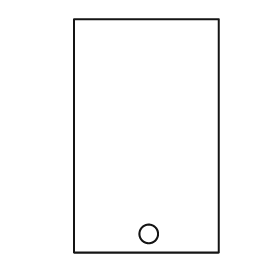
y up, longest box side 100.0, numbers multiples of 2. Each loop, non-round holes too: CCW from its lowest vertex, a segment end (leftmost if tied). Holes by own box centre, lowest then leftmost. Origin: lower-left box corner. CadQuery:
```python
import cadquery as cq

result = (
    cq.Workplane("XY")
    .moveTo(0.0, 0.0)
    .lineTo(62.0, 0.0)
    .lineTo(62.0, 100.0)
    .lineTo(0.0, 100.0)
    .close()
    .moveTo(32.0, 8.0)
    .circle(4.0)
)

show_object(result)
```